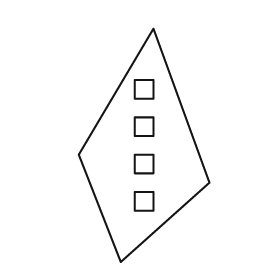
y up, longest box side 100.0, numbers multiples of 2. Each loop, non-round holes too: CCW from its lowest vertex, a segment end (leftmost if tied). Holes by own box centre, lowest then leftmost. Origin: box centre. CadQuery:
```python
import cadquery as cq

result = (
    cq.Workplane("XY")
    .moveTo(-10.0, -50.0)
    .lineTo(28.0, -16.0)
    .lineTo(4.0, 50.0)
    .lineTo(-28.0, -4.0)
    .close()
    .moveTo(-4.0, -28.0)
    .lineTo(4.0, -28.0)
    .lineTo(4.0, -20.0)
    .lineTo(-4.0, -20.0)
    .close()
    .moveTo(-4.0, -12.0)
    .lineTo(4.0, -12.0)
    .lineTo(4.0, -4.0)
    .lineTo(-4.0, -4.0)
    .close()
    .moveTo(-4.0, 4.0)
    .lineTo(4.0, 4.0)
    .lineTo(4.0, 12.0)
    .lineTo(-4.0, 12.0)
    .close()
    .moveTo(-4.0, 20.0)
    .lineTo(4.0, 20.0)
    .lineTo(4.0, 28.0)
    .lineTo(-4.0, 28.0)
    .close()
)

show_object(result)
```